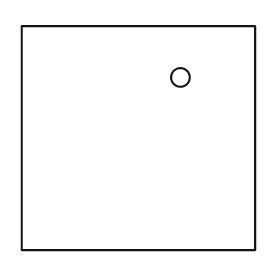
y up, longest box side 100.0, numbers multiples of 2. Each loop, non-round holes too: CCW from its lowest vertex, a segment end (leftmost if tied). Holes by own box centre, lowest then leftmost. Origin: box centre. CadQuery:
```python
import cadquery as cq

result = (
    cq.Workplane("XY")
    .moveTo(-50.0, -48.0)
    .lineTo(50.0, -48.0)
    .lineTo(50.0, 48.0)
    .lineTo(-50.0, 48.0)
    .close()
    .moveTo(18.0, 26.0)
    .circle(4.0)
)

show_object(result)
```